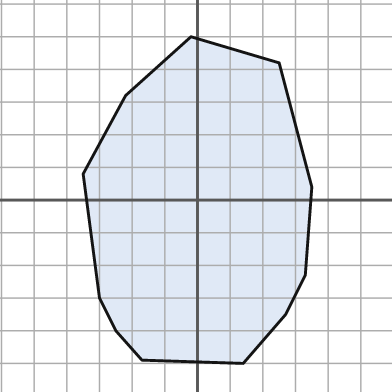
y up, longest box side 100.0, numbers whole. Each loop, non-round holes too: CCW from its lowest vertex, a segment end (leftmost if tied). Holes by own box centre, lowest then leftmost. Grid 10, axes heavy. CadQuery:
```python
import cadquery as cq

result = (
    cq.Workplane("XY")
    .moveTo(14.0, -50.0)
    .lineTo(27.0, -35.0)
    .lineTo(33.0, -23.0)
    .lineTo(35.0, 4.0)
    .lineTo(25.0, 42.0)
    .lineTo(-2.0, 50.0)
    .lineTo(-22.0, 32.0)
    .lineTo(-35.0, 8.0)
    .lineTo(-30.0, -30.0)
    .lineTo(-25.0, -40.0)
    .lineTo(-17.0, -49.0)
    .close()
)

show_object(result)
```